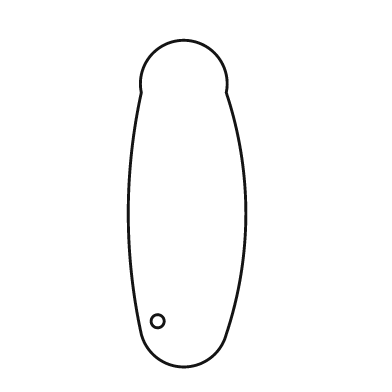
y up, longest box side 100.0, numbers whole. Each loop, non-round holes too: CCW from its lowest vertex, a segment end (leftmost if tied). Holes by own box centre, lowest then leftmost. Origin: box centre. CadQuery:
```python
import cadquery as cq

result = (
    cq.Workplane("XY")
    .moveTo(-14.0, -40.0)
    .threePointArc((-1.0, -50.0), (12.0, -40.0))
    .threePointArc((18.0, -3.0), (12.0, 34.0))
    .threePointArc((-1.0, 50.0), (-14.0, 34.0))
    .threePointArc((-18.0, -3.0), (-14.0, -40.0))
    .close()
    .moveTo(-9.0, -36.0)
    .circle(2.0)
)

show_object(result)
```